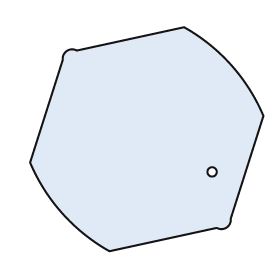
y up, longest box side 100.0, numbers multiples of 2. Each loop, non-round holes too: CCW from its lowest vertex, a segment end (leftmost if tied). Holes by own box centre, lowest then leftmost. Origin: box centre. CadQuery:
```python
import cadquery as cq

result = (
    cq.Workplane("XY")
    .moveTo(-16.0, -48.0)
    .lineTo(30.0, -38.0)
    .threePointArc((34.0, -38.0), (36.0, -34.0))
    .lineTo(50.0, 10.0)
    .threePointArc((36.0, 32.0), (16.0, 48.0))
    .lineTo(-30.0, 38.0)
    .threePointArc((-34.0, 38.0), (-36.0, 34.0))
    .lineTo(-50.0, -10.0)
    .threePointArc((-36.0, -32.0), (-16.0, -48.0))
    .close()
    .moveTo(28.0, -14.0)
    .circle(2.0)
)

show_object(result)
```